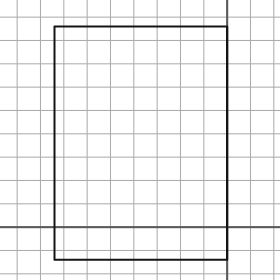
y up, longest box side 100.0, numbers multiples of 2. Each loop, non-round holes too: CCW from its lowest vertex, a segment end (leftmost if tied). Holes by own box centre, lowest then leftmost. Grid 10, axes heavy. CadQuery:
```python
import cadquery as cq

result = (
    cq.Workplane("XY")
    .moveTo(-74.0, -14.0)
    .lineTo(0.0, -14.0)
    .lineTo(0.0, 86.0)
    .lineTo(-74.0, 86.0)
    .close()
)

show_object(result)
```